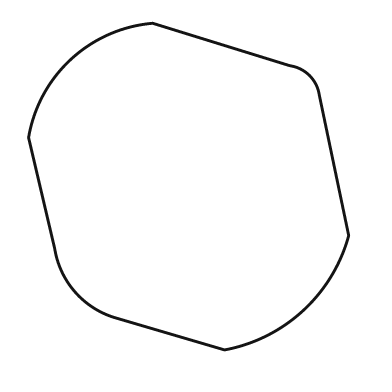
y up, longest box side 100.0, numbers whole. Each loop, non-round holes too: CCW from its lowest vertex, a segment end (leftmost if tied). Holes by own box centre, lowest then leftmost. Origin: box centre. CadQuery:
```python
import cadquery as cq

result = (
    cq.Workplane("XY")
    .moveTo(11.0, -50.0)
    .threePointArc((35.0, -38.0), (49.0, -15.0))
    .lineTo(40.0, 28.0)
    .threePointArc((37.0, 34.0), (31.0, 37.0))
    .lineTo(-11.0, 50.0)
    .threePointArc((-36.0, 39.0), (-49.0, 15.0))
    .lineTo(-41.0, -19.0)
    .threePointArc((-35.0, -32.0), (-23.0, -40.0))
    .close()
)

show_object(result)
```